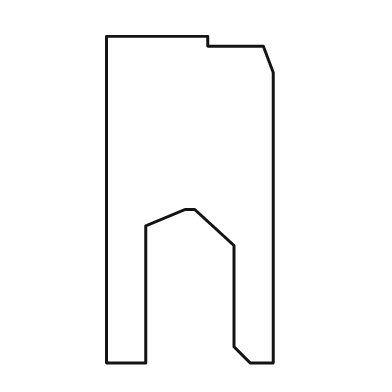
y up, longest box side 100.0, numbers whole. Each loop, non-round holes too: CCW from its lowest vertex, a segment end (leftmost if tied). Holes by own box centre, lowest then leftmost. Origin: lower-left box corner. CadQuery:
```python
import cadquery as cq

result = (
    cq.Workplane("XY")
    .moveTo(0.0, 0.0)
    .lineTo(12.0, 0.0)
    .lineTo(12.0, 42.0)
    .lineTo(24.0, 47.0)
    .lineTo(27.0, 47.0)
    .lineTo(39.0, 36.0)
    .lineTo(39.0, 5.0)
    .lineTo(44.0, 0.0)
    .lineTo(51.0, 0.0)
    .lineTo(51.0, 89.0)
    .lineTo(48.0, 97.0)
    .lineTo(31.0, 97.0)
    .lineTo(31.0, 100.0)
    .lineTo(0.0, 100.0)
    .close()
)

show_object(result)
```